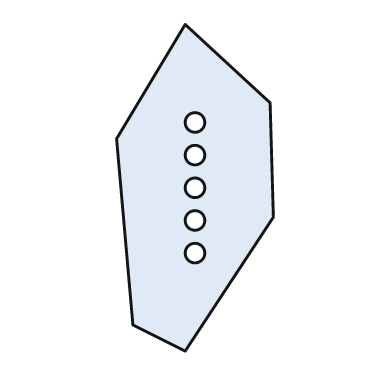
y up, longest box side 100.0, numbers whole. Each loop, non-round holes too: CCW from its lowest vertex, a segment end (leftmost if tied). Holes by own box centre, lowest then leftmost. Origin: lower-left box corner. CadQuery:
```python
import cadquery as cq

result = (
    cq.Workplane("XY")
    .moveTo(21.0, 0.0)
    .lineTo(48.0, 41.0)
    .lineTo(47.0, 76.0)
    .lineTo(21.0, 100.0)
    .lineTo(0.0, 65.0)
    .lineTo(5.0, 8.0)
    .close()
    .moveTo(24.0, 30.0)
    .circle(3.0)
    .moveTo(24.0, 40.0)
    .circle(3.0)
    .moveTo(24.0, 50.0)
    .circle(3.0)
    .moveTo(24.0, 60.0)
    .circle(3.0)
    .moveTo(24.0, 70.0)
    .circle(3.0)
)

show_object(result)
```